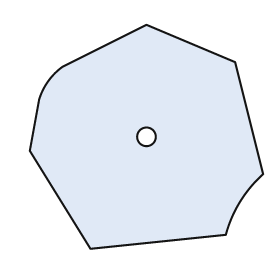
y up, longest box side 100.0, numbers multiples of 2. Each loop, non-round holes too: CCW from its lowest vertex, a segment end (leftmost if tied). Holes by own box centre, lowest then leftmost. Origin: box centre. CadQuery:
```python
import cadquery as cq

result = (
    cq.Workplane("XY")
    .moveTo(-24.0, -48.0)
    .lineTo(34.0, -42.0)
    .threePointArc((40.0, -28.0), (50.0, -16.0))
    .lineTo(38.0, 32.0)
    .lineTo(0.0, 48.0)
    .lineTo(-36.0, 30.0)
    .threePointArc((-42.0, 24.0), (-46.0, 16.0))
    .lineTo(-50.0, -6.0)
    .close()
    .moveTo(0.0, 0.0)
    .circle(4.0)
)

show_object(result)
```